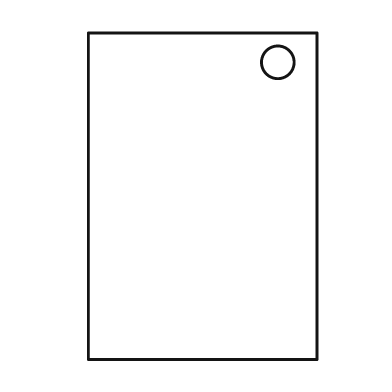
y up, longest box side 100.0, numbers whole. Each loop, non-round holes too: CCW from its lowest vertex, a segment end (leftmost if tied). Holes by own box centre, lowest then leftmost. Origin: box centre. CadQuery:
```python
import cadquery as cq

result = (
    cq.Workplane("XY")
    .moveTo(-35.0, -50.0)
    .lineTo(35.0, -50.0)
    .lineTo(35.0, 50.0)
    .lineTo(-35.0, 50.0)
    .close()
    .moveTo(23.0, 41.0)
    .circle(5.0)
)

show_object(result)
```